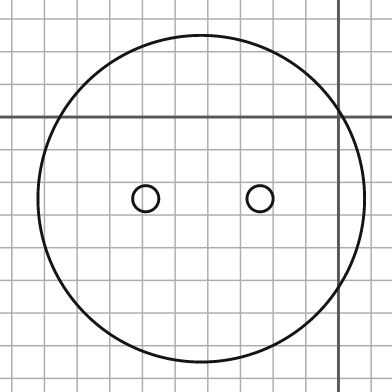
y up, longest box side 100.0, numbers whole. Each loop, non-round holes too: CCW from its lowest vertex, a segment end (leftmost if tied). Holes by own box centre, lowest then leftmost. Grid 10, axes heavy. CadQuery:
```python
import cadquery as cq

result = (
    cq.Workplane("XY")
    .moveTo(-42.0, -25.0)
    .circle(50.0)
    .moveTo(-59.0, -25.0)
    .circle(4.0)
    .moveTo(-24.0, -25.0)
    .circle(4.0)
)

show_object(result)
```